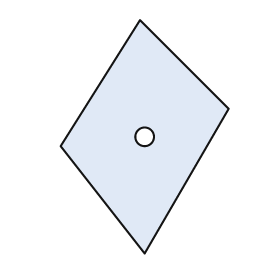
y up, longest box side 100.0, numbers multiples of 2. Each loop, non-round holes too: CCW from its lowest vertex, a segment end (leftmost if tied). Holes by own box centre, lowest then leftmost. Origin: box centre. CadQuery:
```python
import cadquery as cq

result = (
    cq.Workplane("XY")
    .moveTo(0.0, -50.0)
    .lineTo(36.0, 12.0)
    .lineTo(-2.0, 50.0)
    .lineTo(-36.0, -4.0)
    .close()
    .moveTo(0.0, 0.0)
    .circle(4.0)
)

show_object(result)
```